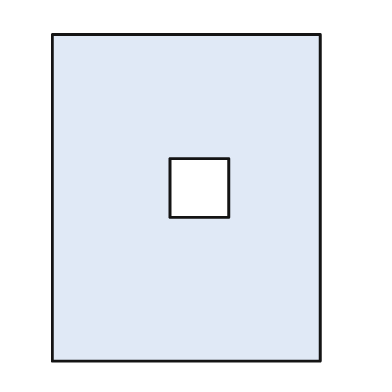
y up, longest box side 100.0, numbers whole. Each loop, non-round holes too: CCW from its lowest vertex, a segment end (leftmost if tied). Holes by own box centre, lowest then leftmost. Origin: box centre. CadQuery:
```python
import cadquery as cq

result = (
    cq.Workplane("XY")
    .moveTo(-41.0, -50.0)
    .lineTo(41.0, -50.0)
    .lineTo(41.0, 50.0)
    .lineTo(-41.0, 50.0)
    .close()
    .moveTo(-5.0, -6.0)
    .lineTo(13.0, -6.0)
    .lineTo(13.0, 12.0)
    .lineTo(-5.0, 12.0)
    .close()
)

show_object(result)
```